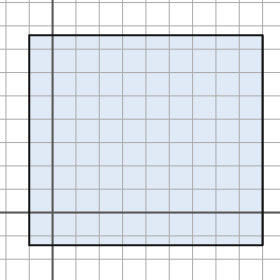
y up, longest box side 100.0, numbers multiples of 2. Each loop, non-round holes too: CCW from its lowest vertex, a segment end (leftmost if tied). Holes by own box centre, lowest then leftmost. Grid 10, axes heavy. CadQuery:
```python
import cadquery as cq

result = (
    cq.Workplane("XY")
    .moveTo(-10.0, -14.0)
    .lineTo(90.0, -14.0)
    .lineTo(90.0, 76.0)
    .lineTo(-10.0, 76.0)
    .close()
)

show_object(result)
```